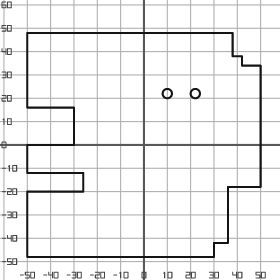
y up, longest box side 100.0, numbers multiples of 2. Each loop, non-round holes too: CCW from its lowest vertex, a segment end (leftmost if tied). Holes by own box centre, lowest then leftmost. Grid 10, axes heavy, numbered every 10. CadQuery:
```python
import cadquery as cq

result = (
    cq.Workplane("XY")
    .moveTo(-50.0, -48.0)
    .lineTo(30.0, -48.0)
    .lineTo(30.0, -42.0)
    .lineTo(36.0, -42.0)
    .lineTo(36.0, -18.0)
    .lineTo(50.0, -18.0)
    .lineTo(50.0, 34.0)
    .lineTo(42.0, 34.0)
    .lineTo(42.0, 38.0)
    .lineTo(38.0, 38.0)
    .lineTo(38.0, 48.0)
    .lineTo(-50.0, 48.0)
    .lineTo(-50.0, 16.0)
    .lineTo(-30.0, 16.0)
    .lineTo(-30.0, 0.0)
    .lineTo(-50.0, 0.0)
    .lineTo(-50.0, -12.0)
    .lineTo(-26.0, -12.0)
    .lineTo(-26.0, -20.0)
    .lineTo(-50.0, -20.0)
    .close()
    .moveTo(10.0, 22.0)
    .circle(2.0)
    .moveTo(22.0, 22.0)
    .circle(2.0)
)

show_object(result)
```